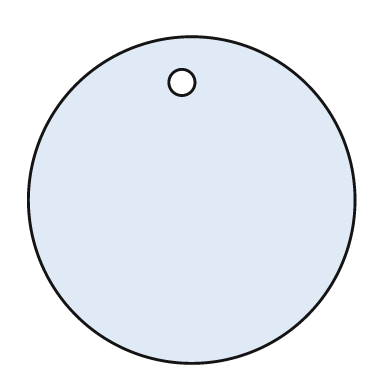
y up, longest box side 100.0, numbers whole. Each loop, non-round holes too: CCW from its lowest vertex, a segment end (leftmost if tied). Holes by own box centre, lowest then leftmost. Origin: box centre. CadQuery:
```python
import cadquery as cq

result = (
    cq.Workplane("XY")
    .moveTo(0.0, 0.0)
    .circle(50.0)
    .moveTo(-3.0, 36.0)
    .circle(4.0)
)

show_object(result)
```